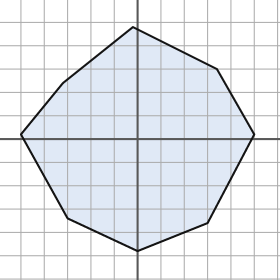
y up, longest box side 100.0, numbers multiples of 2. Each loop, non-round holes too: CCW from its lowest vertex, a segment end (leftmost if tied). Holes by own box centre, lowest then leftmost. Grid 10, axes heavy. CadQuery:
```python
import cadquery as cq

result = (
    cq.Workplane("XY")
    .moveTo(0.0, -48.0)
    .lineTo(30.0, -36.0)
    .lineTo(50.0, 2.0)
    .lineTo(34.0, 30.0)
    .lineTo(-2.0, 48.0)
    .lineTo(-32.0, 24.0)
    .lineTo(-50.0, 2.0)
    .lineTo(-30.0, -34.0)
    .close()
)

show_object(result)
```